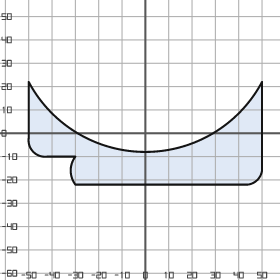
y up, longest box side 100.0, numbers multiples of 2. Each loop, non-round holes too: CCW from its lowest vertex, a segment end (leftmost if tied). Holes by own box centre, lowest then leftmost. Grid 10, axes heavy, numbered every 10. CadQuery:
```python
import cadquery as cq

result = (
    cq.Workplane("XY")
    .moveTo(-30.0, -22.0)
    .lineTo(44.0, -22.0)
    .threePointArc((48.0, -20.0), (50.0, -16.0))
    .lineTo(50.0, 22.0)
    .threePointArc((0.0, -8.0), (-50.0, 22.0))
    .lineTo(-50.0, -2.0)
    .threePointArc((-48.0, -8.0), (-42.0, -10.0))
    .lineTo(-30.0, -10.0)
    .threePointArc((-32.0, -16.0), (-30.0, -22.0))
    .close()
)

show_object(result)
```